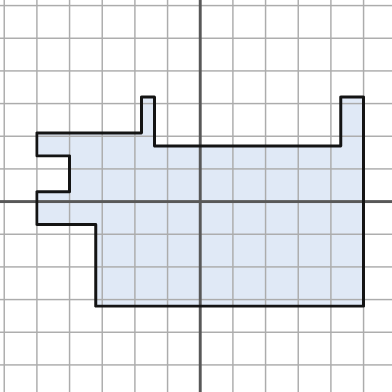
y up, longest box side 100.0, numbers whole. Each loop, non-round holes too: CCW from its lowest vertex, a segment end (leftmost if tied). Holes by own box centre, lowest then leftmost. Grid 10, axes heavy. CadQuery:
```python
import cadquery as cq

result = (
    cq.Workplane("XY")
    .moveTo(-32.0, -32.0)
    .lineTo(50.0, -32.0)
    .lineTo(50.0, 32.0)
    .lineTo(43.0, 32.0)
    .lineTo(43.0, 17.0)
    .lineTo(-14.0, 17.0)
    .lineTo(-14.0, 32.0)
    .lineTo(-18.0, 32.0)
    .lineTo(-18.0, 21.0)
    .lineTo(-50.0, 21.0)
    .lineTo(-50.0, 14.0)
    .lineTo(-40.0, 14.0)
    .lineTo(-40.0, 3.0)
    .lineTo(-50.0, 3.0)
    .lineTo(-50.0, -7.0)
    .lineTo(-32.0, -7.0)
    .close()
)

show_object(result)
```